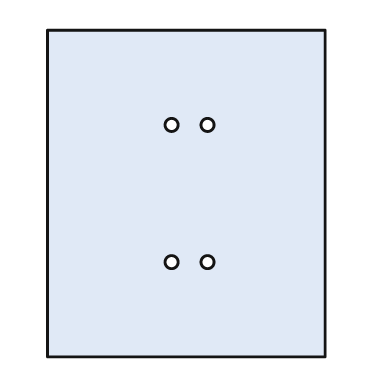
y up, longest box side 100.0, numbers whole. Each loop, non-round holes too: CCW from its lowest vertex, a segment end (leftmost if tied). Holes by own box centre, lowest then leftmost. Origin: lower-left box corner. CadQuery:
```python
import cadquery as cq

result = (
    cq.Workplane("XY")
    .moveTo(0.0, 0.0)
    .lineTo(85.0, 0.0)
    .lineTo(85.0, 100.0)
    .lineTo(0.0, 100.0)
    .close()
    .moveTo(38.0, 29.0)
    .circle(2.0)
    .moveTo(49.0, 29.0)
    .circle(2.0)
    .moveTo(38.0, 71.0)
    .circle(2.0)
    .moveTo(49.0, 71.0)
    .circle(2.0)
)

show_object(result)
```